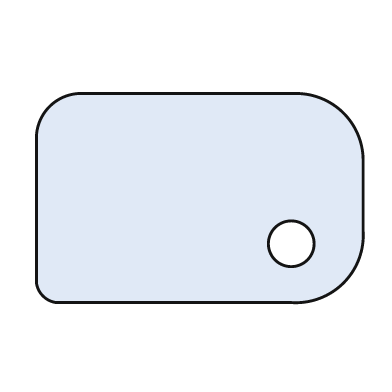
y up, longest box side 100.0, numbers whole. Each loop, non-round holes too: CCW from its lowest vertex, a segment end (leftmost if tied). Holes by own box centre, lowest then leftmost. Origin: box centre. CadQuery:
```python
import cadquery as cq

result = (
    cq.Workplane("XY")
    .moveTo(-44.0, -32.0)
    .lineTo(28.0, -32.0)
    .threePointArc((44.0, -26.0), (50.0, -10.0))
    .lineTo(50.0, 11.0)
    .threePointArc((44.0, 26.0), (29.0, 32.0))
    .lineTo(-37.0, 32.0)
    .threePointArc((-46.0, 28.0), (-50.0, 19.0))
    .lineTo(-50.0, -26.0)
    .threePointArc((-48.0, -30.0), (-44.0, -32.0))
    .close()
    .moveTo(28.0, -14.0)
    .circle(7.0)
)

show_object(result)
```